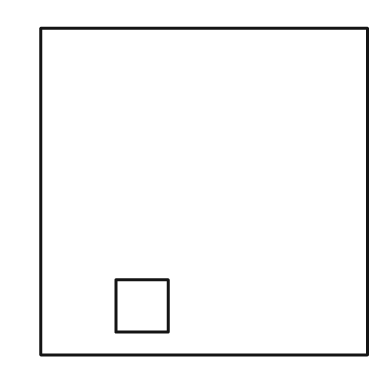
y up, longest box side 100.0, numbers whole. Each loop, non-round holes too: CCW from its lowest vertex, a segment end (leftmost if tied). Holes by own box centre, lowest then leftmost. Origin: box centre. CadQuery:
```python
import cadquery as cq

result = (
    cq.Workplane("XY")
    .moveTo(-50.0, -50.0)
    .lineTo(50.0, -50.0)
    .lineTo(50.0, 50.0)
    .lineTo(-50.0, 50.0)
    .close()
    .moveTo(-27.0, -43.0)
    .lineTo(-11.0, -43.0)
    .lineTo(-11.0, -27.0)
    .lineTo(-27.0, -27.0)
    .close()
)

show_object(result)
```